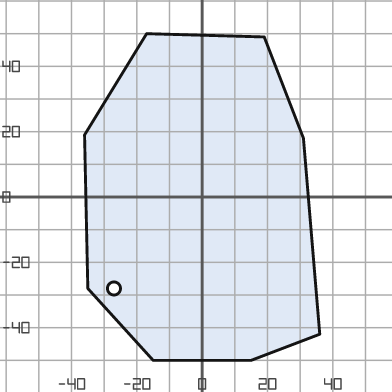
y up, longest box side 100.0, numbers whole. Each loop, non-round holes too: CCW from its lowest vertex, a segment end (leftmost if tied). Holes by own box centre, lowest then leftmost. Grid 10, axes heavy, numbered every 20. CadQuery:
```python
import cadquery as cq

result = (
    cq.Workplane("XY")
    .moveTo(-15.0, -50.0)
    .lineTo(15.0, -50.0)
    .lineTo(36.0, -42.0)
    .lineTo(31.0, 18.0)
    .lineTo(19.0, 49.0)
    .lineTo(-17.0, 50.0)
    .lineTo(-36.0, 19.0)
    .lineTo(-35.0, -28.0)
    .close()
    .moveTo(-27.0, -28.0)
    .circle(2.0)
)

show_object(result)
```